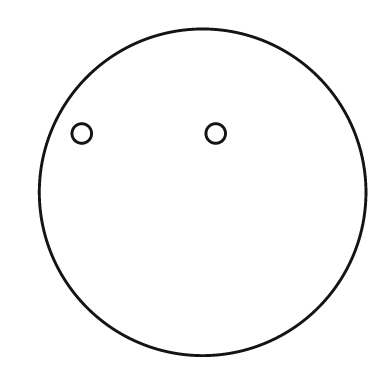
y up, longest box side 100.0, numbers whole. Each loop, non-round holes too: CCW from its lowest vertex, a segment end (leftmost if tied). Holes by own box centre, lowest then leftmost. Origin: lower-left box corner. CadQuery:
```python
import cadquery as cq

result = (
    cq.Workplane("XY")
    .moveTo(50.0, 50.0)
    .circle(50.0)
    .moveTo(13.0, 68.0)
    .circle(3.0)
    .moveTo(54.0, 68.0)
    .circle(3.0)
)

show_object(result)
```